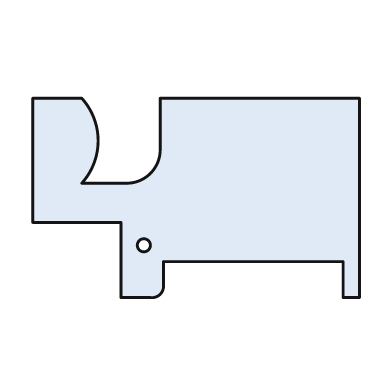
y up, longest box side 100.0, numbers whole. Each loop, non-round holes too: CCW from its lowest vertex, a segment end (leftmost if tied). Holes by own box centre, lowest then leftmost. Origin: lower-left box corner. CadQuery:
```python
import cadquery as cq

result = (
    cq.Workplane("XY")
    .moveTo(27.0, 0.0)
    .lineTo(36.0, 0.0)
    .threePointArc((39.0, 1.0), (40.0, 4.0))
    .lineTo(40.0, 11.0)
    .lineTo(95.0, 11.0)
    .lineTo(95.0, 0.0)
    .lineTo(100.0, 0.0)
    .lineTo(100.0, 61.0)
    .lineTo(39.0, 61.0)
    .lineTo(39.0, 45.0)
    .threePointArc((36.0, 38.0), (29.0, 35.0))
    .lineTo(15.0, 35.0)
    .threePointArc((20.0, 48.0), (15.0, 61.0))
    .lineTo(0.0, 61.0)
    .lineTo(0.0, 23.0)
    .lineTo(27.0, 23.0)
    .close()
    .moveTo(34.0, 16.0)
    .circle(2.0)
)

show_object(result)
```